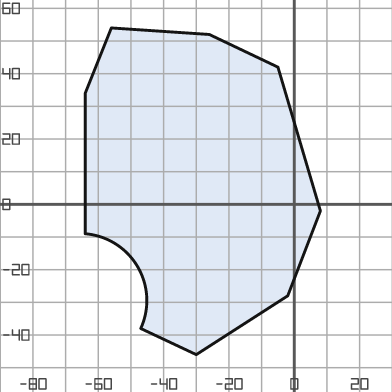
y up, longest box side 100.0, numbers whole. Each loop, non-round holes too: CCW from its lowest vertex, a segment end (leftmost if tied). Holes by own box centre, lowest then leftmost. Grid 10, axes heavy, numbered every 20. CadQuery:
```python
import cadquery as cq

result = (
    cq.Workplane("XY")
    .moveTo(-30.0, -46.0)
    .lineTo(-2.0, -28.0)
    .lineTo(8.0, -2.0)
    .lineTo(-5.0, 42.0)
    .lineTo(-26.0, 52.0)
    .lineTo(-56.0, 54.0)
    .lineTo(-64.0, 34.0)
    .lineTo(-64.0, -9.0)
    .threePointArc((-48.0, -19.0), (-47.0, -38.0))
    .close()
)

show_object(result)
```